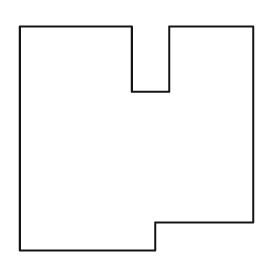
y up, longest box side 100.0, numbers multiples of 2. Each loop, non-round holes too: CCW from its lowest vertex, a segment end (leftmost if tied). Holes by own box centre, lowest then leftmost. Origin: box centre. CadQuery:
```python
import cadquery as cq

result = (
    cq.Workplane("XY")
    .moveTo(-50.0, -48.0)
    .lineTo(8.0, -48.0)
    .lineTo(8.0, -36.0)
    .lineTo(50.0, -36.0)
    .lineTo(50.0, 48.0)
    .lineTo(14.0, 48.0)
    .lineTo(14.0, 20.0)
    .lineTo(-2.0, 20.0)
    .lineTo(-2.0, 48.0)
    .lineTo(-50.0, 48.0)
    .close()
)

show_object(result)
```